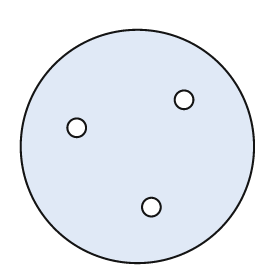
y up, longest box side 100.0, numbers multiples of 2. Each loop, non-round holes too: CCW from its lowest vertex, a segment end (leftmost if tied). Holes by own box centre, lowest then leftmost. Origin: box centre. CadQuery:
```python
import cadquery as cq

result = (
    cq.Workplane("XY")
    .moveTo(0.0, 0.0)
    .circle(50.0)
    .moveTo(6.0, -26.0)
    .circle(4.0)
    .moveTo(-26.0, 8.0)
    .circle(4.0)
    .moveTo(20.0, 20.0)
    .circle(4.0)
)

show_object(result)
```